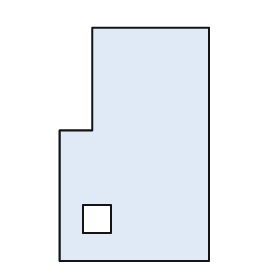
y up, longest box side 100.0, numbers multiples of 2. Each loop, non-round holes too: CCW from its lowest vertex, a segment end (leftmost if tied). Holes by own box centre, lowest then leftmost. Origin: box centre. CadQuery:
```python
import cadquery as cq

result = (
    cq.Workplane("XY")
    .moveTo(-32.0, -50.0)
    .lineTo(32.0, -50.0)
    .lineTo(32.0, 50.0)
    .lineTo(-18.0, 50.0)
    .lineTo(-18.0, 6.0)
    .lineTo(-32.0, 6.0)
    .close()
    .moveTo(-22.0, -38.0)
    .lineTo(-10.0, -38.0)
    .lineTo(-10.0, -26.0)
    .lineTo(-22.0, -26.0)
    .close()
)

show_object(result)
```